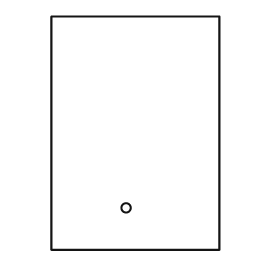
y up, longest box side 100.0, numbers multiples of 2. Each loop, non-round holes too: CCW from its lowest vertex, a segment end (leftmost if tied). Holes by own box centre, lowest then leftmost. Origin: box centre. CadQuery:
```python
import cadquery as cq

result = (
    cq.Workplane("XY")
    .moveTo(-36.0, -50.0)
    .lineTo(36.0, -50.0)
    .lineTo(36.0, 50.0)
    .lineTo(-36.0, 50.0)
    .close()
    .moveTo(-4.0, -32.0)
    .circle(2.0)
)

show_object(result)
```